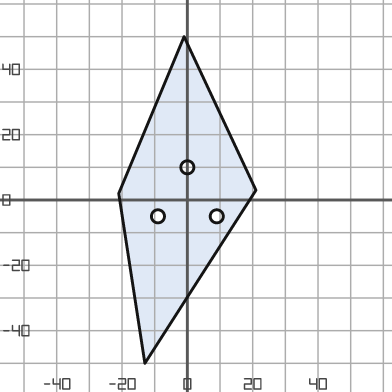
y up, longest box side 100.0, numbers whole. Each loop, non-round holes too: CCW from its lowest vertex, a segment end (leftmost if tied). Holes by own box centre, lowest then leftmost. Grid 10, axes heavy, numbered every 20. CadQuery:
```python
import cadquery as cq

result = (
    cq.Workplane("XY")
    .moveTo(-13.0, -50.0)
    .lineTo(21.0, 3.0)
    .lineTo(-1.0, 50.0)
    .lineTo(-21.0, 2.0)
    .close()
    .moveTo(-9.0, -5.0)
    .circle(2.0)
    .moveTo(9.0, -5.0)
    .circle(2.0)
    .moveTo(0.0, 10.0)
    .circle(2.0)
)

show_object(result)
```